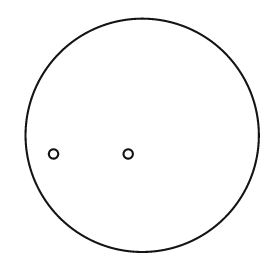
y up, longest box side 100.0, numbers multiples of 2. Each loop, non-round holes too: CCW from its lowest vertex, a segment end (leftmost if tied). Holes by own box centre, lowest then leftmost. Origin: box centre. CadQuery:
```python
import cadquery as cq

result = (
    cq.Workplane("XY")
    .moveTo(0.0, 0.0)
    .circle(50.0)
    .moveTo(-38.0, -8.0)
    .circle(2.0)
    .moveTo(-6.0, -8.0)
    .circle(2.0)
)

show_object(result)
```